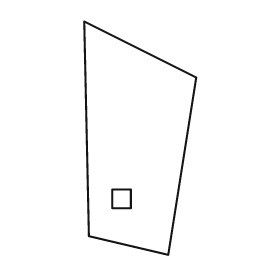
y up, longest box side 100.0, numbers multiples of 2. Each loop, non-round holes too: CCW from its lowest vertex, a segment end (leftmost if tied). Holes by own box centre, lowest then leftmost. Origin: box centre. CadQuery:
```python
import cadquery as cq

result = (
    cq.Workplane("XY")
    .moveTo(12.0, -50.0)
    .lineTo(24.0, 26.0)
    .lineTo(-24.0, 50.0)
    .lineTo(-22.0, -42.0)
    .close()
    .moveTo(-12.0, -30.0)
    .lineTo(-4.0, -30.0)
    .lineTo(-4.0, -22.0)
    .lineTo(-12.0, -22.0)
    .close()
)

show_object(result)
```